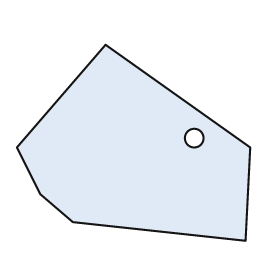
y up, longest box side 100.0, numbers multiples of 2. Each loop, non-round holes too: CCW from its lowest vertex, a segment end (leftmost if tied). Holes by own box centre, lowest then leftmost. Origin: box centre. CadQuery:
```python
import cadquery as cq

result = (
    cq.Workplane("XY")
    .moveTo(48.0, -42.0)
    .lineTo(50.0, -2.0)
    .lineTo(-12.0, 42.0)
    .lineTo(-50.0, -2.0)
    .lineTo(-40.0, -22.0)
    .lineTo(-26.0, -34.0)
    .close()
    .moveTo(26.0, 2.0)
    .circle(4.0)
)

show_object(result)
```